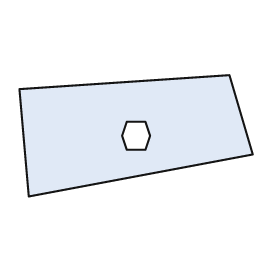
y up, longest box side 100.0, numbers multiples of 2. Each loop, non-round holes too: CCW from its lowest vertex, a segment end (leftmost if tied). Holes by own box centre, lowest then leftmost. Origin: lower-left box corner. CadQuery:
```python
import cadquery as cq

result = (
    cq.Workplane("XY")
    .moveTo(4.0, 0.0)
    .lineTo(100.0, 18.0)
    .lineTo(90.0, 52.0)
    .lineTo(0.0, 46.0)
    .close()
    .moveTo(46.0, 20.0)
    .lineTo(54.0, 20.0)
    .lineTo(56.0, 26.0)
    .lineTo(54.0, 32.0)
    .lineTo(46.0, 32.0)
    .lineTo(44.0, 26.0)
    .close()
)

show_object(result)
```